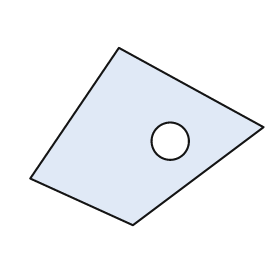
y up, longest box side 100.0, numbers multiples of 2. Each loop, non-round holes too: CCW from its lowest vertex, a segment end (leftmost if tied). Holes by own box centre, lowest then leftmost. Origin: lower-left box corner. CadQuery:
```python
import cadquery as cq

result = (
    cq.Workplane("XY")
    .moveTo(44.0, 0.0)
    .lineTo(100.0, 42.0)
    .lineTo(38.0, 76.0)
    .lineTo(0.0, 20.0)
    .close()
    .moveTo(60.0, 36.0)
    .circle(8.0)
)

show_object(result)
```